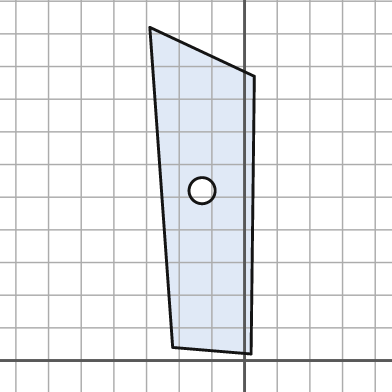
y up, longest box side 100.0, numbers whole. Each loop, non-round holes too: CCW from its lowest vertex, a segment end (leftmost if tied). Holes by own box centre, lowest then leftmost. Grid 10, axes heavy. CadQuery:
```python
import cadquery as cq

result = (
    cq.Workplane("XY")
    .moveTo(2.0, 2.0)
    .lineTo(3.0, 87.0)
    .lineTo(-29.0, 102.0)
    .lineTo(-22.0, 4.0)
    .close()
    .moveTo(-13.0, 52.0)
    .circle(4.0)
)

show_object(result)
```